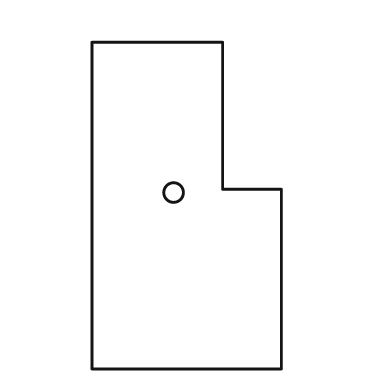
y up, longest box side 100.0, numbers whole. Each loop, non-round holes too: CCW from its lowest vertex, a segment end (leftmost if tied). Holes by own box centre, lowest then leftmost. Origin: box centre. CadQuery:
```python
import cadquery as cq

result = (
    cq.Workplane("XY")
    .moveTo(-29.0, -50.0)
    .lineTo(29.0, -50.0)
    .lineTo(29.0, 5.0)
    .lineTo(11.0, 5.0)
    .lineTo(11.0, 50.0)
    .lineTo(-29.0, 50.0)
    .close()
    .moveTo(-4.0, 4.0)
    .circle(3.0)
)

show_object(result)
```